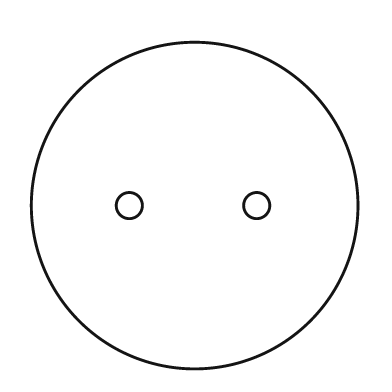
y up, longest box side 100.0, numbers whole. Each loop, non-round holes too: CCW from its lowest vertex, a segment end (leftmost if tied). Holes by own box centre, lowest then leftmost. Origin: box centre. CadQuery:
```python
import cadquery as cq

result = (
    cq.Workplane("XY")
    .moveTo(0.0, 0.0)
    .circle(50.0)
    .moveTo(-20.0, 0.0)
    .circle(4.0)
    .moveTo(19.0, 0.0)
    .circle(4.0)
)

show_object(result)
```